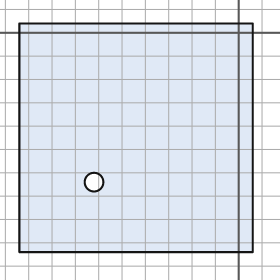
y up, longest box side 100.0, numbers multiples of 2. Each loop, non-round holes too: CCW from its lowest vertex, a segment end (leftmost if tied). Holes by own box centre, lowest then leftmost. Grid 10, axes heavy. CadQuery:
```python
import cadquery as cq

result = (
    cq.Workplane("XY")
    .moveTo(-94.0, -94.0)
    .lineTo(6.0, -94.0)
    .lineTo(6.0, 4.0)
    .lineTo(-94.0, 4.0)
    .close()
    .moveTo(-62.0, -64.0)
    .circle(4.0)
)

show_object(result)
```